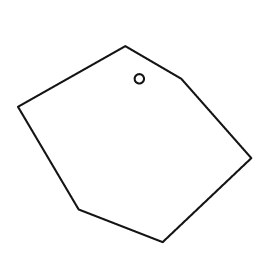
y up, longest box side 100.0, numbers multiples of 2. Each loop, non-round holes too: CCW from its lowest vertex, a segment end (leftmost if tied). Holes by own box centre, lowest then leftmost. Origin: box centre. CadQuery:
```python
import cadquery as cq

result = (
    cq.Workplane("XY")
    .moveTo(12.0, -42.0)
    .lineTo(50.0, -6.0)
    .lineTo(20.0, 28.0)
    .lineTo(-4.0, 42.0)
    .lineTo(-50.0, 16.0)
    .lineTo(-24.0, -28.0)
    .close()
    .moveTo(2.0, 28.0)
    .circle(2.0)
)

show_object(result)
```